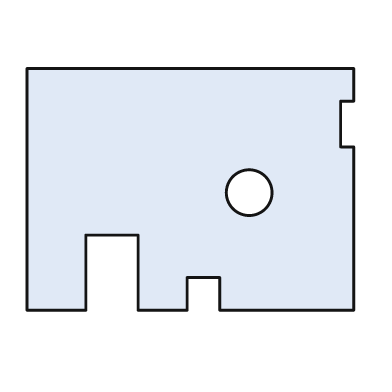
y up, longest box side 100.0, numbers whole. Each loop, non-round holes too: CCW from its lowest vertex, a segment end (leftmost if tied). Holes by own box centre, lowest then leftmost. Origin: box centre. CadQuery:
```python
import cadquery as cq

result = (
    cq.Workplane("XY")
    .moveTo(-50.0, -37.0)
    .lineTo(-32.0, -37.0)
    .lineTo(-32.0, -14.0)
    .lineTo(-16.0, -14.0)
    .lineTo(-16.0, -37.0)
    .lineTo(-1.0, -37.0)
    .lineTo(-1.0, -27.0)
    .lineTo(9.0, -27.0)
    .lineTo(9.0, -37.0)
    .lineTo(50.0, -37.0)
    .lineTo(50.0, 13.0)
    .lineTo(46.0, 13.0)
    .lineTo(46.0, 27.0)
    .lineTo(50.0, 27.0)
    .lineTo(50.0, 37.0)
    .lineTo(-50.0, 37.0)
    .close()
    .moveTo(18.0, -1.0)
    .circle(7.0)
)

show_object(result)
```